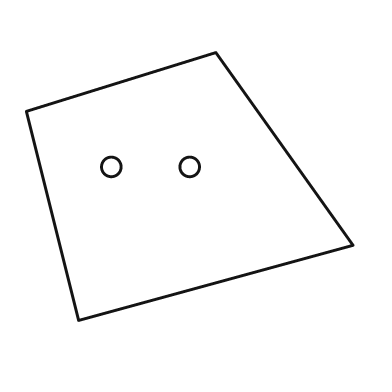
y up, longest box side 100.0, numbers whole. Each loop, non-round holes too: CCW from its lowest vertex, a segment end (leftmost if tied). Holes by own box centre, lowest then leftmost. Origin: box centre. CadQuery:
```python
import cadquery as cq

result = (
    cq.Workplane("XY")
    .moveTo(-34.0, -41.0)
    .lineTo(50.0, -18.0)
    .lineTo(8.0, 41.0)
    .lineTo(-50.0, 23.0)
    .close()
    .moveTo(-24.0, 6.0)
    .circle(3.0)
    .moveTo(0.0, 6.0)
    .circle(3.0)
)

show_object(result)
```